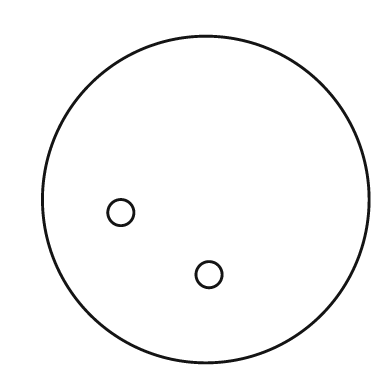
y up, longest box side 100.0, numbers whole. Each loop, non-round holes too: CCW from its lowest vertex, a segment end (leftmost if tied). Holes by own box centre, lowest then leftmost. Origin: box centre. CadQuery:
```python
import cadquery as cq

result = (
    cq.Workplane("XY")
    .moveTo(0.0, 0.0)
    .circle(50.0)
    .moveTo(1.0, -23.0)
    .circle(4.0)
    .moveTo(-26.0, -4.0)
    .circle(4.0)
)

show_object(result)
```